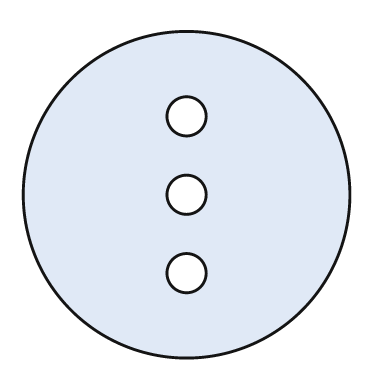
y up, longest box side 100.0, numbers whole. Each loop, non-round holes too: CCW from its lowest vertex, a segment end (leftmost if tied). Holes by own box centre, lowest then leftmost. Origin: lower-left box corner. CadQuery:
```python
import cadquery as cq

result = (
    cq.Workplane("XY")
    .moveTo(50.0, 50.0)
    .circle(50.0)
    .moveTo(50.0, 26.0)
    .circle(6.0)
    .moveTo(50.0, 50.0)
    .circle(6.0)
    .moveTo(50.0, 74.0)
    .circle(6.0)
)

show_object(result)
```